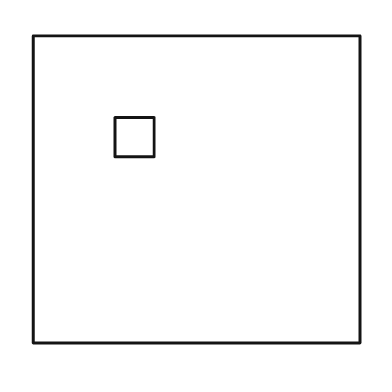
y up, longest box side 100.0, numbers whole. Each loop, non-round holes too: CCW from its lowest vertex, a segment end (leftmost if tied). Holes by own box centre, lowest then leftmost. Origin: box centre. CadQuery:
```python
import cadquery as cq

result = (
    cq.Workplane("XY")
    .moveTo(-50.0, -47.0)
    .lineTo(50.0, -47.0)
    .lineTo(50.0, 47.0)
    .lineTo(-50.0, 47.0)
    .close()
    .moveTo(-25.0, 10.0)
    .lineTo(-13.0, 10.0)
    .lineTo(-13.0, 22.0)
    .lineTo(-25.0, 22.0)
    .close()
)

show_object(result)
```